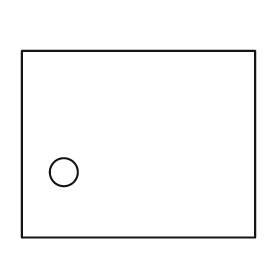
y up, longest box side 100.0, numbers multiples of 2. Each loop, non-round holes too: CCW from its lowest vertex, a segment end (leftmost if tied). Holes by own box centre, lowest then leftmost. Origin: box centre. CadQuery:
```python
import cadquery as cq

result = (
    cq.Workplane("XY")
    .moveTo(-50.0, -40.0)
    .lineTo(50.0, -40.0)
    .lineTo(50.0, 40.0)
    .lineTo(-50.0, 40.0)
    .close()
    .moveTo(-32.0, -12.0)
    .circle(6.0)
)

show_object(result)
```